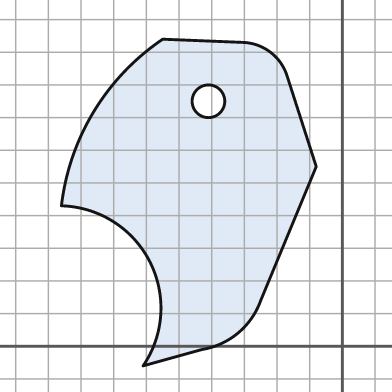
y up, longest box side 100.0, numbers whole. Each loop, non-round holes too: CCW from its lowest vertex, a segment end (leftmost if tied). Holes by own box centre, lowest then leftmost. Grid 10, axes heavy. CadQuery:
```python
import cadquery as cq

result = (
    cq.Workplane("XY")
    .moveTo(-61.0, -6.0)
    .lineTo(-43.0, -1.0)
    .threePointArc((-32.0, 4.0), (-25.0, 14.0))
    .lineTo(-8.0, 55.0)
    .lineTo(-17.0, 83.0)
    .threePointArc((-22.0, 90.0), (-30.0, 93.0))
    .lineTo(-55.0, 94.0)
    .threePointArc((-76.0, 72.0), (-86.0, 43.0))
    .threePointArc((-59.0, 26.0), (-61.0, -6.0))
    .close()
    .moveTo(-41.0, 75.0)
    .circle(5.0)
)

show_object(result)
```